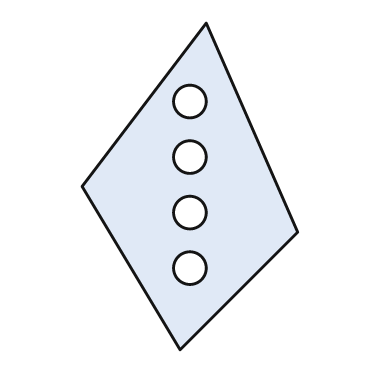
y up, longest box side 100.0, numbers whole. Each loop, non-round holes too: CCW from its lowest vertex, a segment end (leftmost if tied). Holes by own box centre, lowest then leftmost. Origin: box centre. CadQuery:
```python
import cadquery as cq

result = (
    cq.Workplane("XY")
    .moveTo(-3.0, -50.0)
    .lineTo(33.0, -14.0)
    .lineTo(5.0, 50.0)
    .lineTo(-33.0, 0.0)
    .close()
    .moveTo(0.0, -25.0)
    .circle(5.0)
    .moveTo(0.0, -8.0)
    .circle(5.0)
    .moveTo(0.0, 9.0)
    .circle(5.0)
    .moveTo(0.0, 26.0)
    .circle(5.0)
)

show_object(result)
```